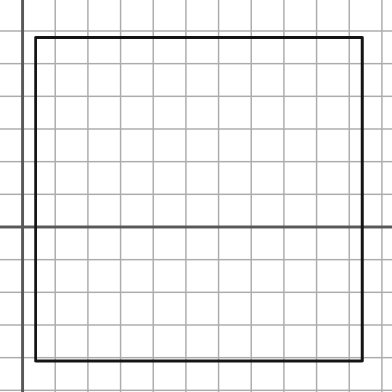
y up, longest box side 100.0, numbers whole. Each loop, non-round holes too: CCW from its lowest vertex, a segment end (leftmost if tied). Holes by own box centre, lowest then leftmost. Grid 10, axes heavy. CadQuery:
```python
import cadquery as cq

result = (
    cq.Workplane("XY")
    .moveTo(4.0, -41.0)
    .lineTo(104.0, -41.0)
    .lineTo(104.0, 58.0)
    .lineTo(4.0, 58.0)
    .close()
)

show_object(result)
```